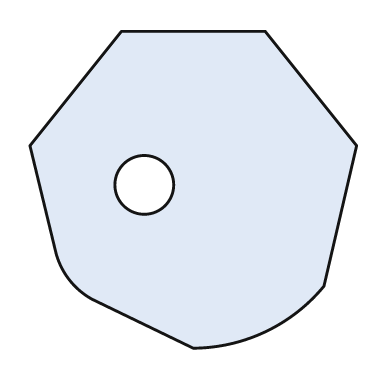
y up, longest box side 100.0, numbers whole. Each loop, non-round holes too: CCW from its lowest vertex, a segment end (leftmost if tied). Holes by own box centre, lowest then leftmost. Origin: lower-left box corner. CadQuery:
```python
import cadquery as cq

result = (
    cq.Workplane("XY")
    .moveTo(50.0, 0.0)
    .threePointArc((72.0, 5.0), (90.0, 19.0))
    .lineTo(100.0, 62.0)
    .lineTo(72.0, 97.0)
    .lineTo(28.0, 97.0)
    .lineTo(0.0, 62.0)
    .lineTo(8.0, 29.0)
    .threePointArc((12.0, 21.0), (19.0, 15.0))
    .close()
    .moveTo(35.0, 50.0)
    .circle(9.0)
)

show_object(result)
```